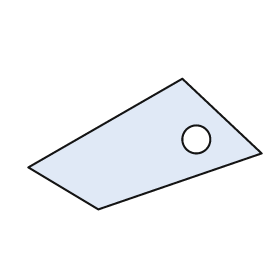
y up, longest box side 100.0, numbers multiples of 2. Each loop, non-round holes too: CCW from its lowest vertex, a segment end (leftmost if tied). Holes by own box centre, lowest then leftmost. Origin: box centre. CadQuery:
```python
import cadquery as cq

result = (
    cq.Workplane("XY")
    .moveTo(-20.0, -28.0)
    .lineTo(50.0, -4.0)
    .lineTo(16.0, 28.0)
    .lineTo(-50.0, -10.0)
    .close()
    .moveTo(22.0, 2.0)
    .circle(6.0)
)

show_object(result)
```